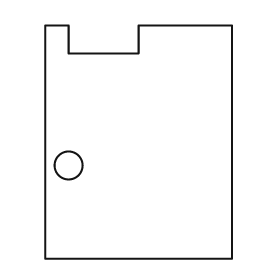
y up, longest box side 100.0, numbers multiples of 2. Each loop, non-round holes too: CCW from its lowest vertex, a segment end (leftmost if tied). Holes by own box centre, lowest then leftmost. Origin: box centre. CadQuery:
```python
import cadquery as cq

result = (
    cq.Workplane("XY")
    .moveTo(-40.0, -50.0)
    .lineTo(40.0, -50.0)
    .lineTo(40.0, 50.0)
    .lineTo(0.0, 50.0)
    .lineTo(0.0, 38.0)
    .lineTo(-30.0, 38.0)
    .lineTo(-30.0, 50.0)
    .lineTo(-40.0, 50.0)
    .close()
    .moveTo(-30.0, -10.0)
    .circle(6.0)
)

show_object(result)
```